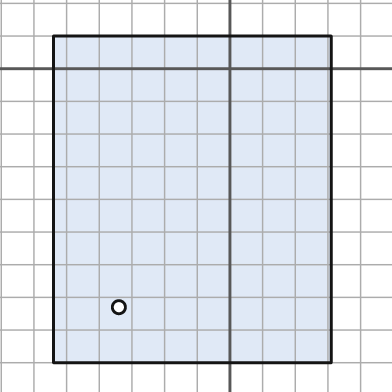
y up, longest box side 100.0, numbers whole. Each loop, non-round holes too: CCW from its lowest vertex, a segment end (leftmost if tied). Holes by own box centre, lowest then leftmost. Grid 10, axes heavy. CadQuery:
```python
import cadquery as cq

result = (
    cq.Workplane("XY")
    .moveTo(-54.0, -90.0)
    .lineTo(31.0, -90.0)
    .lineTo(31.0, 10.0)
    .lineTo(-54.0, 10.0)
    .close()
    .moveTo(-34.0, -73.0)
    .circle(2.0)
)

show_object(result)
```